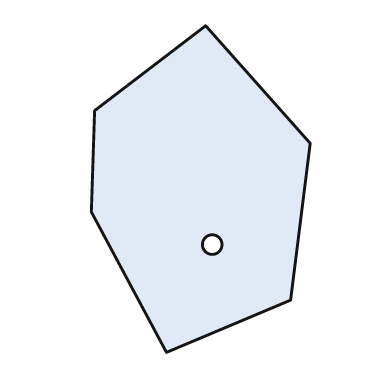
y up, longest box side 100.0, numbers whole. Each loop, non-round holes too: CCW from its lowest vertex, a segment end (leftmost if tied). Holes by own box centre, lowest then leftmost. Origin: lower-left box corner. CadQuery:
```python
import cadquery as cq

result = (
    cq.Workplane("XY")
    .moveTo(23.0, 0.0)
    .lineTo(61.0, 16.0)
    .lineTo(67.0, 64.0)
    .lineTo(35.0, 100.0)
    .lineTo(1.0, 74.0)
    .lineTo(0.0, 43.0)
    .close()
    .moveTo(37.0, 33.0)
    .circle(3.0)
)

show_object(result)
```